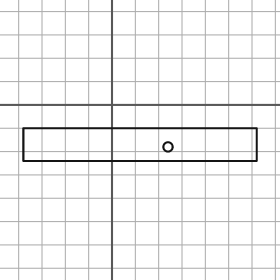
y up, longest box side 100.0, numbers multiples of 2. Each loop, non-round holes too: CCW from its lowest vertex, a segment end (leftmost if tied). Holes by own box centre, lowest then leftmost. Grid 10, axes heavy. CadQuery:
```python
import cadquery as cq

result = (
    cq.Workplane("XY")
    .moveTo(-38.0, -24.0)
    .lineTo(62.0, -24.0)
    .lineTo(62.0, -10.0)
    .lineTo(-38.0, -10.0)
    .close()
    .moveTo(24.0, -18.0)
    .circle(2.0)
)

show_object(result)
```